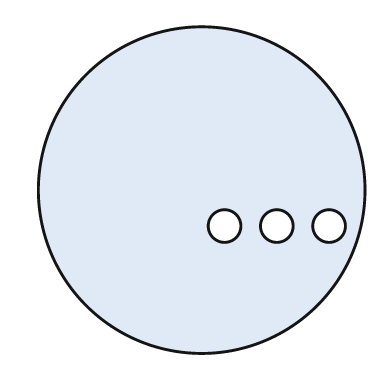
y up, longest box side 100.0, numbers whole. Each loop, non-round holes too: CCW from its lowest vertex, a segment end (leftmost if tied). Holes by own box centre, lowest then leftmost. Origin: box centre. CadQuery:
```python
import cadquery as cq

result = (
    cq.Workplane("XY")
    .moveTo(0.0, 0.0)
    .circle(50.0)
    .moveTo(7.0, -11.0)
    .circle(5.0)
    .moveTo(23.0, -11.0)
    .circle(5.0)
    .moveTo(39.0, -11.0)
    .circle(5.0)
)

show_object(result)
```